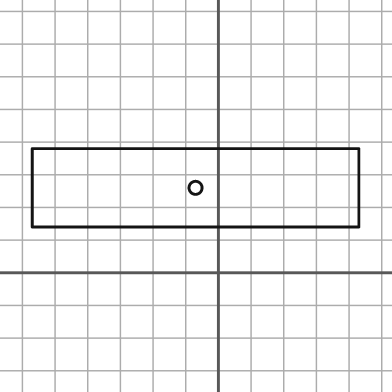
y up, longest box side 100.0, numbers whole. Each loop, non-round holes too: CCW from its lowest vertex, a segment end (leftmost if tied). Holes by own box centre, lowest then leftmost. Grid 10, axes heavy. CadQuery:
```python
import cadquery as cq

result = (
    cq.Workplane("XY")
    .moveTo(-57.0, 14.0)
    .lineTo(43.0, 14.0)
    .lineTo(43.0, 38.0)
    .lineTo(-57.0, 38.0)
    .close()
    .moveTo(-7.0, 26.0)
    .circle(2.0)
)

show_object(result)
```